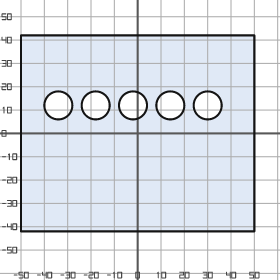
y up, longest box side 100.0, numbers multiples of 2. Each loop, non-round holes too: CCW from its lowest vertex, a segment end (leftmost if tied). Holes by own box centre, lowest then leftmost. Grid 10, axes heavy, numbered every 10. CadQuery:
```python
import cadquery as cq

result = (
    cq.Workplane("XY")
    .moveTo(-50.0, -42.0)
    .lineTo(50.0, -42.0)
    .lineTo(50.0, 42.0)
    .lineTo(-50.0, 42.0)
    .close()
    .moveTo(-34.0, 12.0)
    .circle(6.0)
    .moveTo(-18.0, 12.0)
    .circle(6.0)
    .moveTo(-2.0, 12.0)
    .circle(6.0)
    .moveTo(14.0, 12.0)
    .circle(6.0)
    .moveTo(30.0, 12.0)
    .circle(6.0)
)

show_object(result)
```